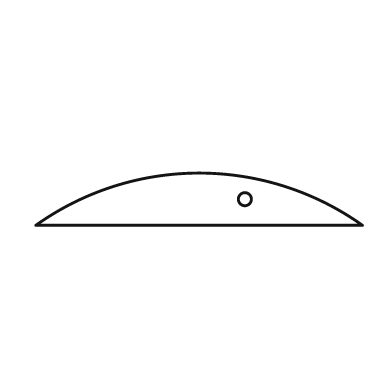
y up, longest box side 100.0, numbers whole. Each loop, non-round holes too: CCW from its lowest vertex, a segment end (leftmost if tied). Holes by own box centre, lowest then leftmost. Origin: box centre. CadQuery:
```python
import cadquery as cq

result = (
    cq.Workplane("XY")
    .moveTo(-50.0, -8.0)
    .lineTo(50.0, -8.0)
    .threePointArc((0.0, 8.0), (-50.0, -8.0))
    .close()
    .moveTo(14.0, 0.0)
    .circle(2.0)
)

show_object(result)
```